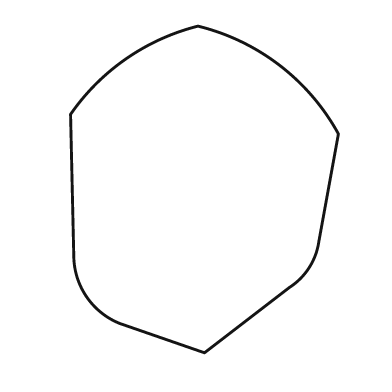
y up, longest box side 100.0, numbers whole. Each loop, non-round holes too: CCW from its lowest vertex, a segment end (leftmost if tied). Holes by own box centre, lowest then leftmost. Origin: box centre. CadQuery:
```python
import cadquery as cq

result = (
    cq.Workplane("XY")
    .moveTo(0.0, -50.0)
    .lineTo(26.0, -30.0)
    .threePointArc((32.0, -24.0), (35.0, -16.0))
    .lineTo(41.0, 17.0)
    .threePointArc((23.0, 38.0), (-2.0, 50.0))
    .threePointArc((-24.0, 40.0), (-41.0, 23.0))
    .lineTo(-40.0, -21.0)
    .threePointArc((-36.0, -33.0), (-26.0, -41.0))
    .close()
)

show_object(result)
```